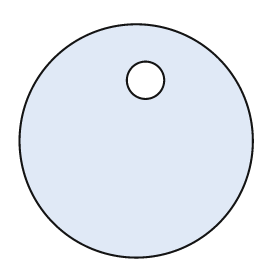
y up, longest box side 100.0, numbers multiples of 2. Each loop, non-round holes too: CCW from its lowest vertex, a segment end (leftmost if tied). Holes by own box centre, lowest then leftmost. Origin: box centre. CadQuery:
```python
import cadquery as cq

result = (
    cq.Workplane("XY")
    .moveTo(0.0, 0.0)
    .circle(50.0)
    .moveTo(4.0, 26.0)
    .circle(8.0)
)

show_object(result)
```